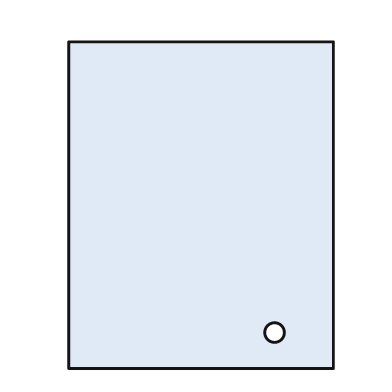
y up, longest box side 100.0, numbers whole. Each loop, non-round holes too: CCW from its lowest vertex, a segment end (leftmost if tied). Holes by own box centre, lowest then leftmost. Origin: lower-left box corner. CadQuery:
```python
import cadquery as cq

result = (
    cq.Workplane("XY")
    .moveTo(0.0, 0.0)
    .lineTo(81.0, 0.0)
    .lineTo(81.0, 100.0)
    .lineTo(0.0, 100.0)
    .close()
    .moveTo(63.0, 11.0)
    .circle(3.0)
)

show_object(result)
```